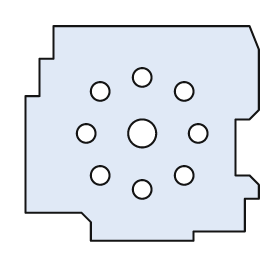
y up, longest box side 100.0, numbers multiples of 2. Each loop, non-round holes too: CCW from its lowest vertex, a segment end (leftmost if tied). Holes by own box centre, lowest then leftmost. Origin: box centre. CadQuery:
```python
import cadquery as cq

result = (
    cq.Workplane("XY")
    .moveTo(-22.0, -46.0)
    .lineTo(22.0, -46.0)
    .lineTo(22.0, -42.0)
    .lineTo(44.0, -42.0)
    .lineTo(44.0, -28.0)
    .lineTo(50.0, -28.0)
    .lineTo(50.0, -22.0)
    .lineTo(46.0, -18.0)
    .lineTo(40.0, -18.0)
    .lineTo(40.0, 6.0)
    .lineTo(46.0, 6.0)
    .lineTo(50.0, 10.0)
    .lineTo(50.0, 36.0)
    .lineTo(46.0, 46.0)
    .lineTo(-38.0, 46.0)
    .lineTo(-38.0, 32.0)
    .lineTo(-44.0, 32.0)
    .lineTo(-44.0, 16.0)
    .lineTo(-50.0, 16.0)
    .lineTo(-50.0, -34.0)
    .lineTo(-26.0, -34.0)
    .lineTo(-22.0, -38.0)
    .close()
    .moveTo(0.0, -24.0)
    .circle(4.0)
    .moveTo(-18.0, -18.0)
    .circle(4.0)
    .moveTo(18.0, -18.0)
    .circle(4.0)
    .moveTo(-24.0, 0.0)
    .circle(4.0)
    .moveTo(0.0, 0.0)
    .circle(6.0)
    .moveTo(24.0, 0.0)
    .circle(4.0)
    .moveTo(-18.0, 18.0)
    .circle(4.0)
    .moveTo(18.0, 18.0)
    .circle(4.0)
    .moveTo(0.0, 24.0)
    .circle(4.0)
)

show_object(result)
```